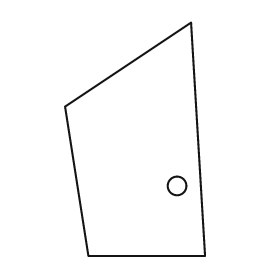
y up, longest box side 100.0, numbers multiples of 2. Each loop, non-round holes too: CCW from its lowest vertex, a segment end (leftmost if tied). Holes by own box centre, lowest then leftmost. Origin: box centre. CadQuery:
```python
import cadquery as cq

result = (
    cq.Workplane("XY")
    .moveTo(-20.0, -50.0)
    .lineTo(30.0, -50.0)
    .lineTo(24.0, 50.0)
    .lineTo(-30.0, 14.0)
    .close()
    .moveTo(18.0, -20.0)
    .circle(4.0)
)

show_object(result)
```